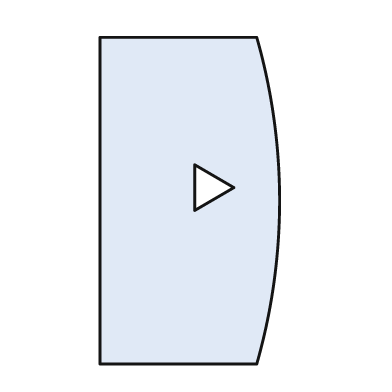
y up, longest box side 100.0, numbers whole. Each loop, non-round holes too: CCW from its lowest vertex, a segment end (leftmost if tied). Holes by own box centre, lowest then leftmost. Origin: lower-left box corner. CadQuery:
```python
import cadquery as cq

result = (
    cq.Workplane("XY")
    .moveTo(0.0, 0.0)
    .lineTo(48.0, 0.0)
    .threePointArc((55.0, 50.0), (48.0, 100.0))
    .lineTo(0.0, 100.0)
    .close()
    .moveTo(29.0, 47.0)
    .lineTo(41.0, 54.0)
    .lineTo(29.0, 61.0)
    .close()
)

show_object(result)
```